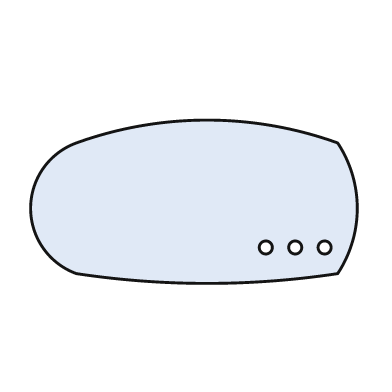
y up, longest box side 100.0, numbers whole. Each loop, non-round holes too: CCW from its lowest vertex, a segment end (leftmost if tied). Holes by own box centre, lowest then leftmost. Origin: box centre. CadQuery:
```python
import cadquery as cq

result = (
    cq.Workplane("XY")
    .moveTo(-36.0, -22.0)
    .threePointArc((4.0, -25.0), (44.0, -22.0))
    .threePointArc((50.0, -2.0), (44.0, 18.0))
    .threePointArc((4.0, 25.0), (-36.0, 18.0))
    .threePointArc((-50.0, -2.0), (-36.0, -22.0))
    .close()
    .moveTo(22.0, -14.0)
    .circle(2.0)
    .moveTo(31.0, -14.0)
    .circle(2.0)
    .moveTo(40.0, -14.0)
    .circle(2.0)
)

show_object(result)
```